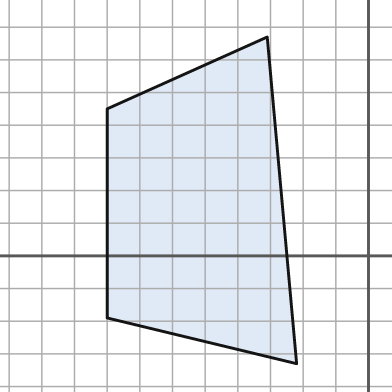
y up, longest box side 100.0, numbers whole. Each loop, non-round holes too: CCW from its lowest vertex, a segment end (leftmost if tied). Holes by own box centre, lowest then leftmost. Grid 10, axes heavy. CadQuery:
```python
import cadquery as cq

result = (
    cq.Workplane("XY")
    .moveTo(-22.0, -33.0)
    .lineTo(-31.0, 67.0)
    .lineTo(-80.0, 45.0)
    .lineTo(-80.0, -19.0)
    .close()
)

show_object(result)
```